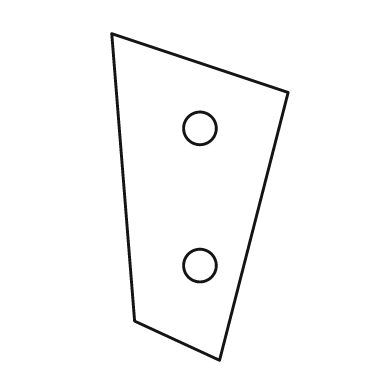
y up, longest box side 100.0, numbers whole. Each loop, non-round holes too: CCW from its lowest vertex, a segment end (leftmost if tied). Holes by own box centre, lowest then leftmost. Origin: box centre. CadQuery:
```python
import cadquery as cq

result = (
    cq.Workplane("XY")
    .moveTo(6.0, -50.0)
    .lineTo(27.0, 32.0)
    .lineTo(-27.0, 50.0)
    .lineTo(-20.0, -38.0)
    .close()
    .moveTo(0.0, -21.0)
    .circle(5.0)
    .moveTo(0.0, 21.0)
    .circle(5.0)
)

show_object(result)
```